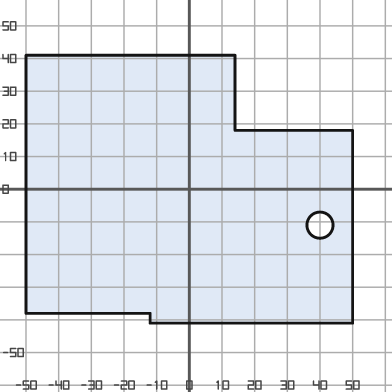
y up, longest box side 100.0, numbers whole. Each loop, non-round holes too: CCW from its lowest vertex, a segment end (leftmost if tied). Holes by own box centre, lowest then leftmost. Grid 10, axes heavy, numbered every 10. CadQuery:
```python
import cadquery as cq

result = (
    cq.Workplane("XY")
    .moveTo(-12.0, -41.0)
    .lineTo(50.0, -41.0)
    .lineTo(50.0, 18.0)
    .lineTo(14.0, 18.0)
    .lineTo(14.0, 41.0)
    .lineTo(-50.0, 41.0)
    .lineTo(-50.0, -38.0)
    .lineTo(-12.0, -38.0)
    .close()
    .moveTo(40.0, -11.0)
    .circle(4.0)
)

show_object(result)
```